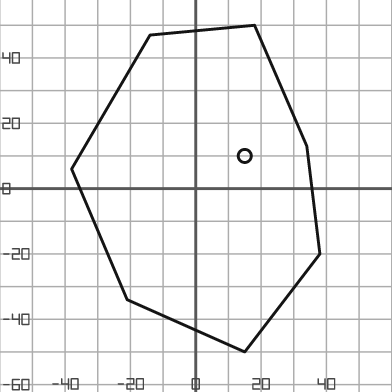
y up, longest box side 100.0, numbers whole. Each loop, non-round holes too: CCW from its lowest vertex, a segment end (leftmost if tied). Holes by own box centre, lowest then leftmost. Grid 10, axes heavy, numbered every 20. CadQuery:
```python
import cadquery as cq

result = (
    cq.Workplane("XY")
    .moveTo(15.0, -50.0)
    .lineTo(38.0, -20.0)
    .lineTo(34.0, 13.0)
    .lineTo(18.0, 50.0)
    .lineTo(-14.0, 47.0)
    .lineTo(-38.0, 6.0)
    .lineTo(-21.0, -34.0)
    .close()
    .moveTo(15.0, 10.0)
    .circle(2.0)
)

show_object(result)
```